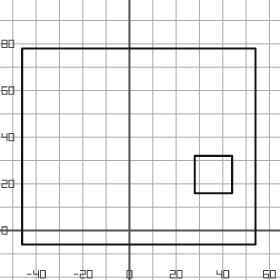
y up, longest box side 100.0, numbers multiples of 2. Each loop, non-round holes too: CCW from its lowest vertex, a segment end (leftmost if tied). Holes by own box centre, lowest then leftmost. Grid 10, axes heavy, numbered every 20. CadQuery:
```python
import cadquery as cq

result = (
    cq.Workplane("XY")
    .moveTo(-46.0, -6.0)
    .lineTo(54.0, -6.0)
    .lineTo(54.0, 78.0)
    .lineTo(-46.0, 78.0)
    .close()
    .moveTo(28.0, 16.0)
    .lineTo(44.0, 16.0)
    .lineTo(44.0, 32.0)
    .lineTo(28.0, 32.0)
    .close()
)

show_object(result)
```